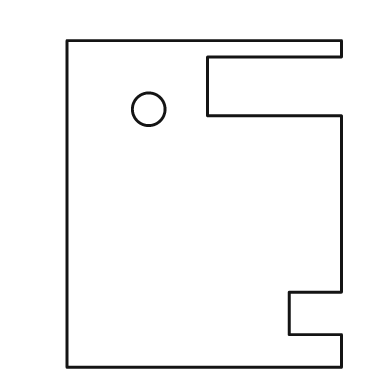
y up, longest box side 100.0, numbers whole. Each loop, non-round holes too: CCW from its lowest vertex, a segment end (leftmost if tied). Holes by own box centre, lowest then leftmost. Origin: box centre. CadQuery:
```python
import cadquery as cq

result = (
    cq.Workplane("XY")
    .moveTo(-42.0, -50.0)
    .lineTo(42.0, -50.0)
    .lineTo(42.0, -40.0)
    .lineTo(26.0, -40.0)
    .lineTo(26.0, -27.0)
    .lineTo(42.0, -27.0)
    .lineTo(42.0, 27.0)
    .lineTo(1.0, 27.0)
    .lineTo(1.0, 45.0)
    .lineTo(42.0, 45.0)
    .lineTo(42.0, 50.0)
    .lineTo(-42.0, 50.0)
    .close()
    .moveTo(-17.0, 29.0)
    .circle(5.0)
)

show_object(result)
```